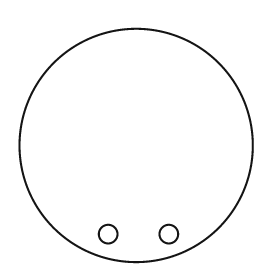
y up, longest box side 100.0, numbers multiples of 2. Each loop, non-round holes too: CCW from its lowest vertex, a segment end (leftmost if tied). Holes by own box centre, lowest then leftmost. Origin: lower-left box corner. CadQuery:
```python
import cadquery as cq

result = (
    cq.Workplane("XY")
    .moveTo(50.0, 50.0)
    .circle(50.0)
    .moveTo(38.0, 12.0)
    .circle(4.0)
    .moveTo(64.0, 12.0)
    .circle(4.0)
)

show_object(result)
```